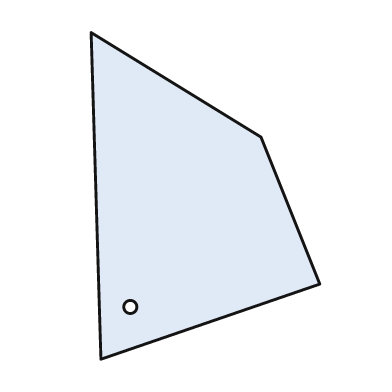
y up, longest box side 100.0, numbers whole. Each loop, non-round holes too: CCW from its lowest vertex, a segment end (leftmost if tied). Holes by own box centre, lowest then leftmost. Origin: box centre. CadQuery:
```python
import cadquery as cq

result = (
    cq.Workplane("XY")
    .moveTo(-32.0, -50.0)
    .lineTo(35.0, -27.0)
    .lineTo(17.0, 18.0)
    .lineTo(-35.0, 50.0)
    .close()
    .moveTo(-23.0, -34.0)
    .circle(2.0)
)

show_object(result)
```